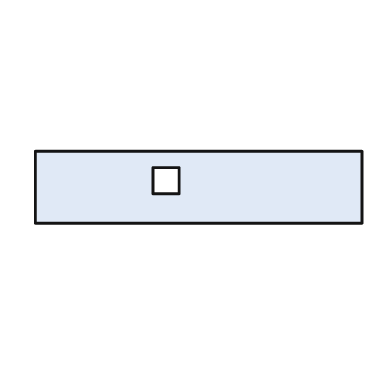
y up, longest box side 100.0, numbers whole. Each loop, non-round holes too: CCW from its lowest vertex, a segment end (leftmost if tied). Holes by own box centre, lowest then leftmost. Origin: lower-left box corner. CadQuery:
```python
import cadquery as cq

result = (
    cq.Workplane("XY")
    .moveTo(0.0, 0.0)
    .lineTo(100.0, 0.0)
    .lineTo(100.0, 22.0)
    .lineTo(0.0, 22.0)
    .close()
    .moveTo(36.0, 9.0)
    .lineTo(44.0, 9.0)
    .lineTo(44.0, 17.0)
    .lineTo(36.0, 17.0)
    .close()
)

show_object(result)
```